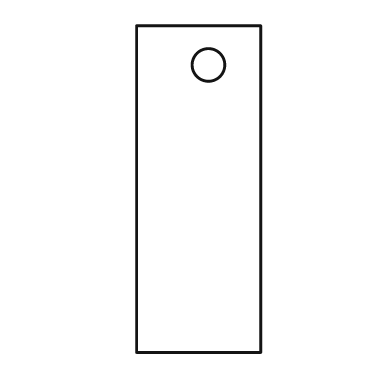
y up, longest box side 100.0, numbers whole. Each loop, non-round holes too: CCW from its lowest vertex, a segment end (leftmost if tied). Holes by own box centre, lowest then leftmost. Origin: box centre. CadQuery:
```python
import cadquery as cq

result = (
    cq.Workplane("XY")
    .moveTo(-19.0, -50.0)
    .lineTo(19.0, -50.0)
    .lineTo(19.0, 50.0)
    .lineTo(-19.0, 50.0)
    .close()
    .moveTo(3.0, 38.0)
    .circle(5.0)
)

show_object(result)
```